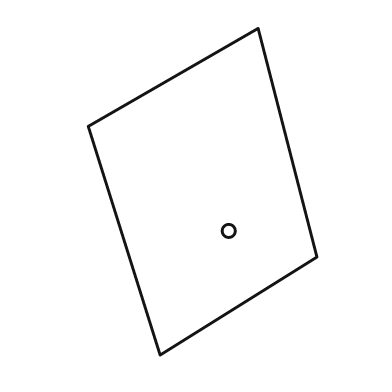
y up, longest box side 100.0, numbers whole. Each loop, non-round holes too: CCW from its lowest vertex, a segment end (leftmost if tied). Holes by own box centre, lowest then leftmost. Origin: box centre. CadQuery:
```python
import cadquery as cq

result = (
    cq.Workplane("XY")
    .moveTo(-13.0, -50.0)
    .lineTo(35.0, -20.0)
    .lineTo(17.0, 50.0)
    .lineTo(-35.0, 20.0)
    .close()
    .moveTo(8.0, -12.0)
    .circle(2.0)
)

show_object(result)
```